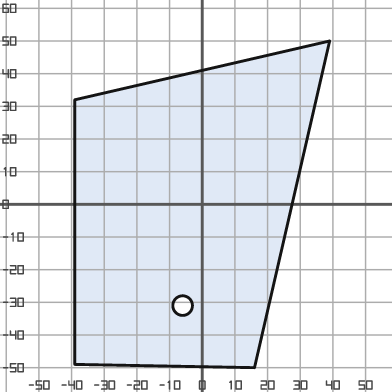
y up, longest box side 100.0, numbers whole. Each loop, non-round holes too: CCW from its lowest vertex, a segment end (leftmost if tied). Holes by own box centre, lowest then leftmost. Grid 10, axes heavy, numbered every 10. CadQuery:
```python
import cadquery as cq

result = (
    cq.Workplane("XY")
    .moveTo(16.0, -50.0)
    .lineTo(39.0, 50.0)
    .lineTo(-39.0, 32.0)
    .lineTo(-39.0, -49.0)
    .close()
    .moveTo(-6.0, -31.0)
    .circle(3.0)
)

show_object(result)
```